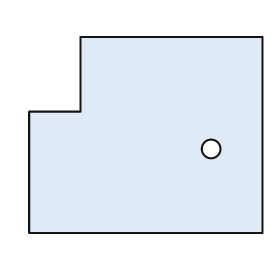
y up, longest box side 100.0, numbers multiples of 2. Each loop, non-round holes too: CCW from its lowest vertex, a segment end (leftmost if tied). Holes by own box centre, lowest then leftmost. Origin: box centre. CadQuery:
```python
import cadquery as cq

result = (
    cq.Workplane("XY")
    .moveTo(-50.0, -42.0)
    .lineTo(50.0, -42.0)
    .lineTo(50.0, 42.0)
    .lineTo(-28.0, 42.0)
    .lineTo(-28.0, 10.0)
    .lineTo(-50.0, 10.0)
    .close()
    .moveTo(28.0, -6.0)
    .circle(4.0)
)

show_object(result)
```